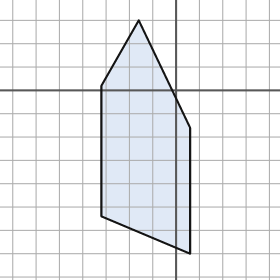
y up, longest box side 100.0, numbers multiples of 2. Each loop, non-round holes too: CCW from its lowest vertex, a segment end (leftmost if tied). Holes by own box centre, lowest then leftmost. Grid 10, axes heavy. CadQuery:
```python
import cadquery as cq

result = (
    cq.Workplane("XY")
    .moveTo(6.0, -70.0)
    .lineTo(6.0, -16.0)
    .lineTo(-16.0, 30.0)
    .lineTo(-32.0, 2.0)
    .lineTo(-32.0, -54.0)
    .close()
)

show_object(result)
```